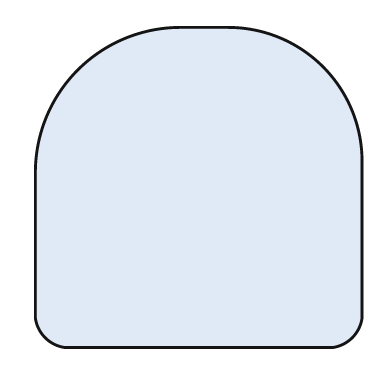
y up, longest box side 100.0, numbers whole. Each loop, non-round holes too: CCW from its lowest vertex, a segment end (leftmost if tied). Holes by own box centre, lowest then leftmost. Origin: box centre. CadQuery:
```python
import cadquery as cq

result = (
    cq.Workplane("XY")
    .moveTo(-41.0, -49.0)
    .lineTo(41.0, -49.0)
    .threePointArc((47.0, -46.0), (50.0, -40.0))
    .lineTo(50.0, 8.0)
    .threePointArc((38.0, 37.0), (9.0, 49.0))
    .lineTo(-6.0, 49.0)
    .threePointArc((-37.0, 36.0), (-50.0, 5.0))
    .lineTo(-50.0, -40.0)
    .threePointArc((-47.0, -46.0), (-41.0, -49.0))
    .close()
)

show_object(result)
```